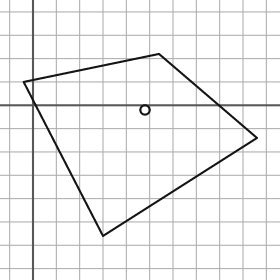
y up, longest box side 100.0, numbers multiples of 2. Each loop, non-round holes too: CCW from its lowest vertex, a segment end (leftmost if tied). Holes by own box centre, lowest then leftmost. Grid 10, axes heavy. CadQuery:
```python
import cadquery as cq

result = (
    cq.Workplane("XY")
    .moveTo(30.0, -56.0)
    .lineTo(96.0, -14.0)
    .lineTo(54.0, 22.0)
    .lineTo(-4.0, 10.0)
    .close()
    .moveTo(48.0, -2.0)
    .circle(2.0)
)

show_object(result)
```